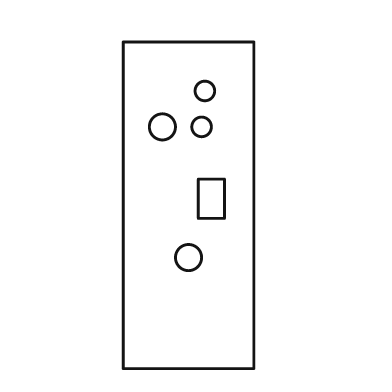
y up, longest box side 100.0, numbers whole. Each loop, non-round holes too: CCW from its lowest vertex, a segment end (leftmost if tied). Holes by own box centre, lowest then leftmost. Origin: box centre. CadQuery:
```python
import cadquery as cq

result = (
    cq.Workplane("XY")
    .moveTo(-20.0, -50.0)
    .lineTo(20.0, -50.0)
    .lineTo(20.0, 50.0)
    .lineTo(-20.0, 50.0)
    .close()
    .moveTo(0.0, -16.0)
    .circle(4.0)
    .moveTo(3.0, -4.0)
    .lineTo(11.0, -4.0)
    .lineTo(11.0, 8.0)
    .lineTo(3.0, 8.0)
    .close()
    .moveTo(-8.0, 24.0)
    .circle(4.0)
    .moveTo(4.0, 24.0)
    .circle(3.0)
    .moveTo(5.0, 35.0)
    .circle(3.0)
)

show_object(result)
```